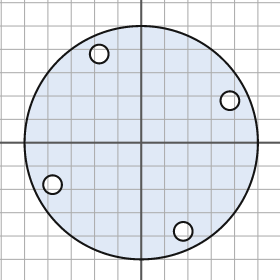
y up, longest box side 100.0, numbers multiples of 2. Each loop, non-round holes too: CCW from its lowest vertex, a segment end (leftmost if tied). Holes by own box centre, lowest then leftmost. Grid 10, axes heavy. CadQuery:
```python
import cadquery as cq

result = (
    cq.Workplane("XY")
    .moveTo(0.0, 0.0)
    .circle(50.0)
    .moveTo(18.0, -38.0)
    .circle(4.0)
    .moveTo(-38.0, -18.0)
    .circle(4.0)
    .moveTo(38.0, 18.0)
    .circle(4.0)
    .moveTo(-18.0, 38.0)
    .circle(4.0)
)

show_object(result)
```